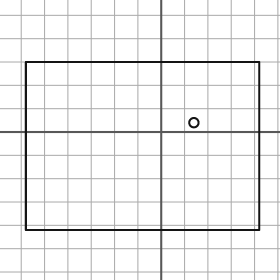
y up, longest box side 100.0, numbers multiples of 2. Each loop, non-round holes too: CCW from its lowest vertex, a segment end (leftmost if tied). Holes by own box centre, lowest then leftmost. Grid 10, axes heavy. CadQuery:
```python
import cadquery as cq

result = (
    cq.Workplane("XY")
    .moveTo(-58.0, -42.0)
    .lineTo(42.0, -42.0)
    .lineTo(42.0, 30.0)
    .lineTo(-58.0, 30.0)
    .close()
    .moveTo(14.0, 4.0)
    .circle(2.0)
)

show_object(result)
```